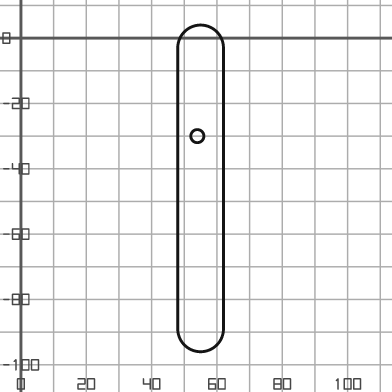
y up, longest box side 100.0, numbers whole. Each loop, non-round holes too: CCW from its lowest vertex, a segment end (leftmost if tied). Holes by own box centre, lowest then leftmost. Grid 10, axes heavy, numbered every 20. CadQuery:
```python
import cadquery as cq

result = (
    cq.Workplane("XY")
    .moveTo(48.0, -89.0)
    .threePointArc((55.0, -96.0), (62.0, -89.0))
    .lineTo(62.0, -3.0)
    .threePointArc((55.0, 4.0), (48.0, -3.0))
    .close()
    .moveTo(54.0, -30.0)
    .circle(2.0)
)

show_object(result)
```